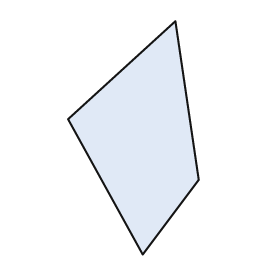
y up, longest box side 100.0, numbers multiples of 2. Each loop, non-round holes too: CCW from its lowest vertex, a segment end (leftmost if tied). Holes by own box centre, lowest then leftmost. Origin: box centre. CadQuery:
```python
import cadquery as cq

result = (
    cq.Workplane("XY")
    .moveTo(4.0, -50.0)
    .lineTo(28.0, -18.0)
    .lineTo(18.0, 50.0)
    .lineTo(-28.0, 8.0)
    .close()
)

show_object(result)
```